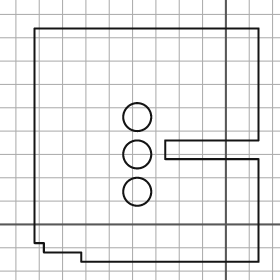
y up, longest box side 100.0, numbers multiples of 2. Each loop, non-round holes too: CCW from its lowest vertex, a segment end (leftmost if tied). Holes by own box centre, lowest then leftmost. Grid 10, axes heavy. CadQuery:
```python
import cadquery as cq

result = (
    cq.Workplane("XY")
    .moveTo(-62.0, -16.0)
    .lineTo(14.0, -16.0)
    .lineTo(14.0, 28.0)
    .lineTo(-26.0, 28.0)
    .lineTo(-26.0, 36.0)
    .lineTo(14.0, 36.0)
    .lineTo(14.0, 84.0)
    .lineTo(-82.0, 84.0)
    .lineTo(-82.0, -8.0)
    .lineTo(-78.0, -8.0)
    .lineTo(-78.0, -12.0)
    .lineTo(-62.0, -12.0)
    .close()
    .moveTo(-38.0, 14.0)
    .circle(6.0)
    .moveTo(-38.0, 30.0)
    .circle(6.0)
    .moveTo(-38.0, 46.0)
    .circle(6.0)
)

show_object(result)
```